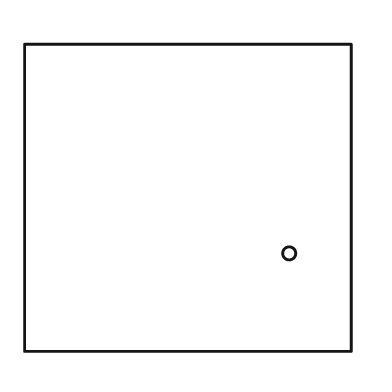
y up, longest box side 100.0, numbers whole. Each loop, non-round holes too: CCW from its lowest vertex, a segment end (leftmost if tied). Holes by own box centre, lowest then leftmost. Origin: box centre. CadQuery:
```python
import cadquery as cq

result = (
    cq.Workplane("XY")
    .moveTo(-50.0, -47.0)
    .lineTo(50.0, -47.0)
    .lineTo(50.0, 47.0)
    .lineTo(-50.0, 47.0)
    .close()
    .moveTo(31.0, -17.0)
    .circle(2.0)
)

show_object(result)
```